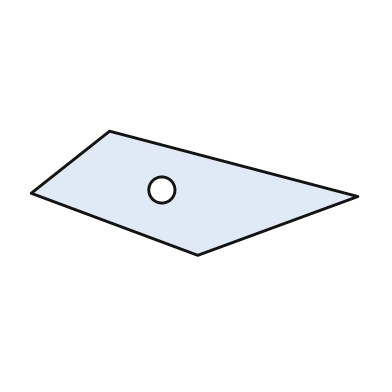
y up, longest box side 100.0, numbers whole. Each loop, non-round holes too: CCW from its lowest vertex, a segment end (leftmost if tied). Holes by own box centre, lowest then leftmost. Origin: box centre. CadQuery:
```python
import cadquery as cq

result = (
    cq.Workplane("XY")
    .moveTo(1.0, -19.0)
    .lineTo(50.0, -1.0)
    .lineTo(-26.0, 19.0)
    .lineTo(-50.0, 0.0)
    .close()
    .moveTo(-10.0, 1.0)
    .circle(4.0)
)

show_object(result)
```